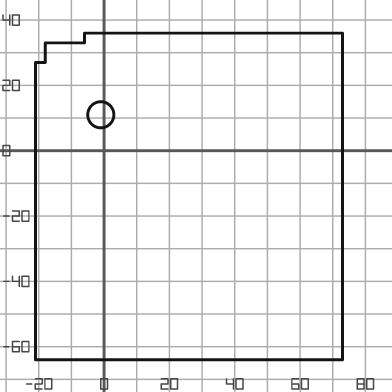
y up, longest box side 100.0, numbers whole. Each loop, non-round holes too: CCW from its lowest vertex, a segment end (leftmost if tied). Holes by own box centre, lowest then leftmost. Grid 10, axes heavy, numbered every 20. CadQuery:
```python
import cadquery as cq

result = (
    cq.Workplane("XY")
    .moveTo(-21.0, -64.0)
    .lineTo(73.0, -64.0)
    .lineTo(73.0, 36.0)
    .lineTo(-6.0, 36.0)
    .lineTo(-6.0, 33.0)
    .lineTo(-18.0, 33.0)
    .lineTo(-18.0, 27.0)
    .lineTo(-21.0, 27.0)
    .close()
    .moveTo(-1.0, 11.0)
    .circle(4.0)
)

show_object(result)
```